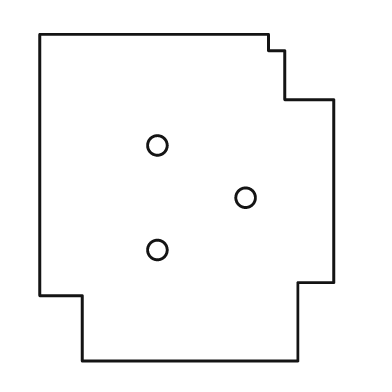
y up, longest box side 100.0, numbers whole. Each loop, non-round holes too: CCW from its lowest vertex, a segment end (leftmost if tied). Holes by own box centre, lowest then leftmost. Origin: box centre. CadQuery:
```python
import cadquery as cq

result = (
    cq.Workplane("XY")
    .moveTo(-32.0, -50.0)
    .lineTo(34.0, -50.0)
    .lineTo(34.0, -26.0)
    .lineTo(45.0, -26.0)
    .lineTo(45.0, 30.0)
    .lineTo(30.0, 30.0)
    .lineTo(30.0, 45.0)
    .lineTo(25.0, 45.0)
    .lineTo(25.0, 50.0)
    .lineTo(-45.0, 50.0)
    .lineTo(-45.0, -30.0)
    .lineTo(-32.0, -30.0)
    .close()
    .moveTo(-9.0, -16.0)
    .circle(3.0)
    .moveTo(18.0, 0.0)
    .circle(3.0)
    .moveTo(-9.0, 16.0)
    .circle(3.0)
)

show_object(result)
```